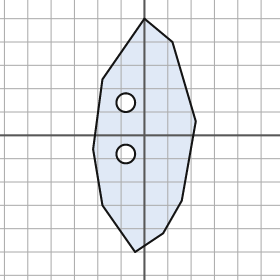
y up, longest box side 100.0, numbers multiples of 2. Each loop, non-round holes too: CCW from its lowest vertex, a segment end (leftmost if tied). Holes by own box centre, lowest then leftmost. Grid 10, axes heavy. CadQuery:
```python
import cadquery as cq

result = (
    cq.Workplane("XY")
    .moveTo(-4.0, -50.0)
    .lineTo(8.0, -42.0)
    .lineTo(16.0, -28.0)
    .lineTo(22.0, 6.0)
    .lineTo(12.0, 40.0)
    .lineTo(0.0, 50.0)
    .lineTo(-18.0, 24.0)
    .lineTo(-22.0, -6.0)
    .lineTo(-18.0, -30.0)
    .close()
    .moveTo(-8.0, -8.0)
    .circle(4.0)
    .moveTo(-8.0, 14.0)
    .circle(4.0)
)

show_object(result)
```